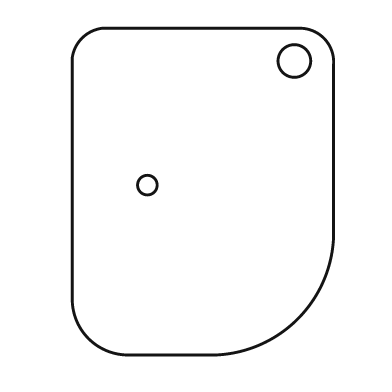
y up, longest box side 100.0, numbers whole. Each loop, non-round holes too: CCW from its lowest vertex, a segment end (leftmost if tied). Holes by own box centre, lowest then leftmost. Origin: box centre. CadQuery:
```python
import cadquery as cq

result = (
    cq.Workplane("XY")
    .moveTo(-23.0, -50.0)
    .lineTo(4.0, -50.0)
    .threePointArc((29.0, -39.0), (40.0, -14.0))
    .lineTo(40.0, 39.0)
    .threePointArc((37.0, 47.0), (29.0, 50.0))
    .lineTo(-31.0, 50.0)
    .threePointArc((-37.0, 47.0), (-40.0, 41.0))
    .lineTo(-40.0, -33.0)
    .threePointArc((-35.0, -45.0), (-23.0, -50.0))
    .close()
    .moveTo(-17.0, 2.0)
    .circle(3.0)
    .moveTo(28.0, 40.0)
    .circle(5.0)
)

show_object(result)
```